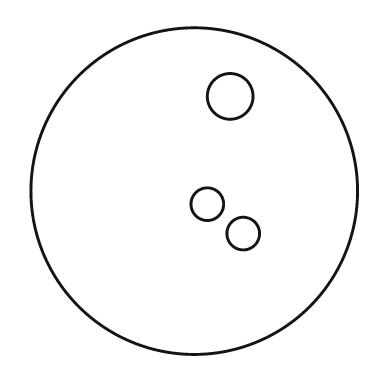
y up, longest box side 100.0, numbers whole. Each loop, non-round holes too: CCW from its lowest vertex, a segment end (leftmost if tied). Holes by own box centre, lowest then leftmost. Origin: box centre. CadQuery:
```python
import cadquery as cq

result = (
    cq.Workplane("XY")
    .moveTo(0.0, 0.0)
    .circle(50.0)
    .moveTo(15.0, -13.0)
    .circle(5.0)
    .moveTo(4.0, -4.0)
    .circle(5.0)
    .moveTo(11.0, 29.0)
    .circle(7.0)
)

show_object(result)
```